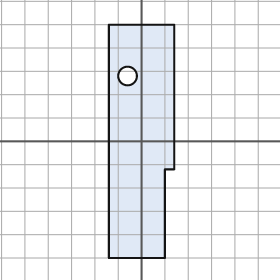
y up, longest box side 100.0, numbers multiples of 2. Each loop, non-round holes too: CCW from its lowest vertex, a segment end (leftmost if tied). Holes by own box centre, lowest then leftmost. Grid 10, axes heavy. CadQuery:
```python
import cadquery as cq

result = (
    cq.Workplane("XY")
    .moveTo(-14.0, -50.0)
    .lineTo(10.0, -50.0)
    .lineTo(10.0, -12.0)
    .lineTo(14.0, -12.0)
    .lineTo(14.0, 50.0)
    .lineTo(-14.0, 50.0)
    .close()
    .moveTo(-6.0, 28.0)
    .circle(4.0)
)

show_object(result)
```